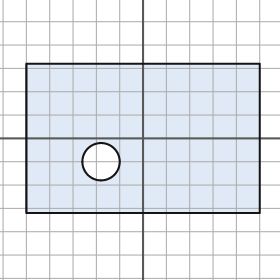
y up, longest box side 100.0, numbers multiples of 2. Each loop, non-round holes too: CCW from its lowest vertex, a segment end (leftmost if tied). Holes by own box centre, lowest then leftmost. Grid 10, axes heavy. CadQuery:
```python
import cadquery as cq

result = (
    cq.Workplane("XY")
    .moveTo(-50.0, -32.0)
    .lineTo(50.0, -32.0)
    .lineTo(50.0, 32.0)
    .lineTo(-50.0, 32.0)
    .close()
    .moveTo(-18.0, -10.0)
    .circle(8.0)
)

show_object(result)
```